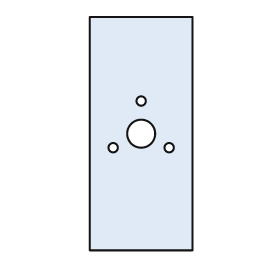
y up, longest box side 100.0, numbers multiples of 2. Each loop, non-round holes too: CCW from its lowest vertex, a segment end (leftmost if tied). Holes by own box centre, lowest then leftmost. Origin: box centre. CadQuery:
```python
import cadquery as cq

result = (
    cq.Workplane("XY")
    .moveTo(-22.0, -50.0)
    .lineTo(22.0, -50.0)
    .lineTo(22.0, 50.0)
    .lineTo(-22.0, 50.0)
    .close()
    .moveTo(-12.0, -6.0)
    .circle(2.0)
    .moveTo(12.0, -6.0)
    .circle(2.0)
    .moveTo(0.0, 0.0)
    .circle(6.0)
    .moveTo(0.0, 14.0)
    .circle(2.0)
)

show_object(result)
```